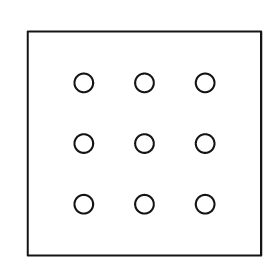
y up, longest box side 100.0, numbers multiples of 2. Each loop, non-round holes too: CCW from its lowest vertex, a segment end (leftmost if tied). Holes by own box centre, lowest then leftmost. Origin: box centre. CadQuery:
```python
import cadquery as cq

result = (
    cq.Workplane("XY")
    .moveTo(-50.0, -48.0)
    .lineTo(50.0, -48.0)
    .lineTo(50.0, 48.0)
    .lineTo(-50.0, 48.0)
    .close()
    .moveTo(-26.0, -26.0)
    .circle(4.0)
    .moveTo(0.0, -26.0)
    .circle(4.0)
    .moveTo(26.0, -26.0)
    .circle(4.0)
    .moveTo(-26.0, 0.0)
    .circle(4.0)
    .moveTo(0.0, 0.0)
    .circle(4.0)
    .moveTo(26.0, 0.0)
    .circle(4.0)
    .moveTo(-26.0, 26.0)
    .circle(4.0)
    .moveTo(0.0, 26.0)
    .circle(4.0)
    .moveTo(26.0, 26.0)
    .circle(4.0)
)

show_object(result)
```